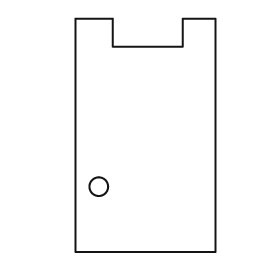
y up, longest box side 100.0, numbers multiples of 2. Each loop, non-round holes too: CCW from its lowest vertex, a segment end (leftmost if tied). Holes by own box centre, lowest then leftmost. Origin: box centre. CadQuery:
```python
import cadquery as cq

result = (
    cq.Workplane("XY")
    .moveTo(-30.0, -50.0)
    .lineTo(30.0, -50.0)
    .lineTo(30.0, 50.0)
    .lineTo(16.0, 50.0)
    .lineTo(16.0, 38.0)
    .lineTo(-14.0, 38.0)
    .lineTo(-14.0, 50.0)
    .lineTo(-30.0, 50.0)
    .close()
    .moveTo(-20.0, -22.0)
    .circle(4.0)
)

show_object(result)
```